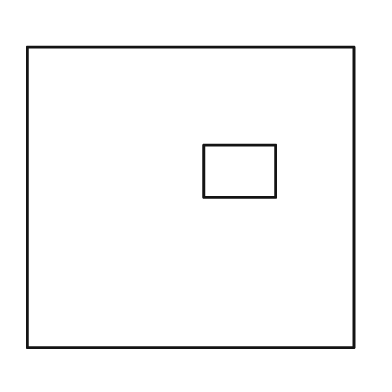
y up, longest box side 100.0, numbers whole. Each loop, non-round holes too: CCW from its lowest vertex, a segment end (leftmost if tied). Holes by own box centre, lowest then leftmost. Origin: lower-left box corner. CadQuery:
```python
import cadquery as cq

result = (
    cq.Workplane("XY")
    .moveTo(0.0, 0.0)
    .lineTo(100.0, 0.0)
    .lineTo(100.0, 92.0)
    .lineTo(0.0, 92.0)
    .close()
    .moveTo(54.0, 46.0)
    .lineTo(76.0, 46.0)
    .lineTo(76.0, 62.0)
    .lineTo(54.0, 62.0)
    .close()
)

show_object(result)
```